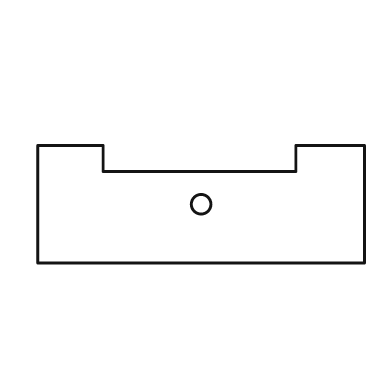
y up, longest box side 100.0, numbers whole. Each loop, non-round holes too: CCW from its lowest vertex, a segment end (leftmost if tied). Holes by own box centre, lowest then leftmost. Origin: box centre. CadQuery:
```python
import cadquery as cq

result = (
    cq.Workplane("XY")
    .moveTo(-50.0, -18.0)
    .lineTo(50.0, -18.0)
    .lineTo(50.0, 18.0)
    .lineTo(29.0, 18.0)
    .lineTo(29.0, 10.0)
    .lineTo(-30.0, 10.0)
    .lineTo(-30.0, 18.0)
    .lineTo(-50.0, 18.0)
    .close()
    .moveTo(0.0, 0.0)
    .circle(3.0)
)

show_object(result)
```